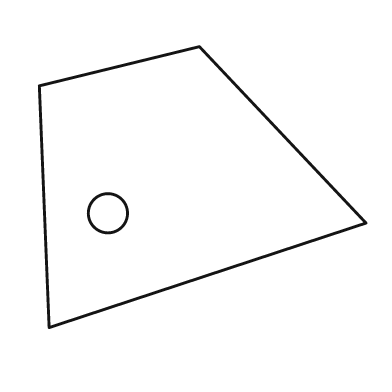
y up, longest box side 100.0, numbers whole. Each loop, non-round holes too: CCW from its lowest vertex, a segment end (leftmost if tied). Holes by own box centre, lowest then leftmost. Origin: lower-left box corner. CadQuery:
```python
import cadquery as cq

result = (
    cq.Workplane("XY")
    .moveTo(3.0, 0.0)
    .lineTo(100.0, 32.0)
    .lineTo(49.0, 86.0)
    .lineTo(0.0, 74.0)
    .close()
    .moveTo(21.0, 35.0)
    .circle(6.0)
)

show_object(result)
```